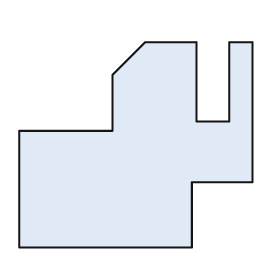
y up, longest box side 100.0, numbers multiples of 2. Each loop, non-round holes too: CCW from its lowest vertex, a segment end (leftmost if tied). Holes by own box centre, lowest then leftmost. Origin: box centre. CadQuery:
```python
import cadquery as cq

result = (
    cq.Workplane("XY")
    .moveTo(-50.0, -44.0)
    .lineTo(24.0, -44.0)
    .lineTo(24.0, -16.0)
    .lineTo(50.0, -16.0)
    .lineTo(50.0, 44.0)
    .lineTo(40.0, 44.0)
    .lineTo(40.0, 10.0)
    .lineTo(26.0, 10.0)
    .lineTo(26.0, 44.0)
    .lineTo(4.0, 44.0)
    .lineTo(-10.0, 30.0)
    .lineTo(-10.0, 6.0)
    .lineTo(-50.0, 6.0)
    .close()
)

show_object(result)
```